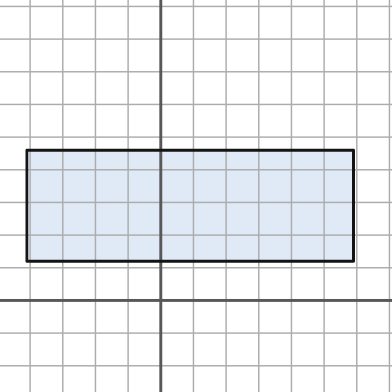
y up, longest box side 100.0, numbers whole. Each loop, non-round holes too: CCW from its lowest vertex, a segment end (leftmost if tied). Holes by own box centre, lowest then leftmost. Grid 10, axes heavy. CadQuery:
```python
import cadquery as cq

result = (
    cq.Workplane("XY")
    .moveTo(-41.0, 12.0)
    .lineTo(59.0, 12.0)
    .lineTo(59.0, 46.0)
    .lineTo(-41.0, 46.0)
    .close()
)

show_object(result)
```